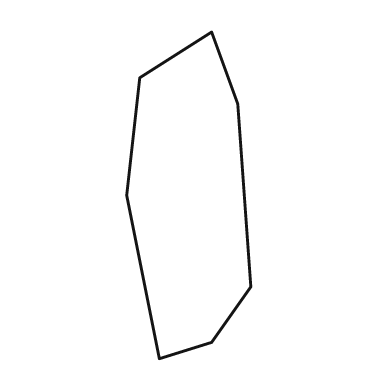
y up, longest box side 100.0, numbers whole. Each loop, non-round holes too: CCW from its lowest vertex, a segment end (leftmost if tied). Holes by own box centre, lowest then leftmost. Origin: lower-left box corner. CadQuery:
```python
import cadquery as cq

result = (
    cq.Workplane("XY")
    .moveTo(10.0, 0.0)
    .lineTo(26.0, 5.0)
    .lineTo(38.0, 22.0)
    .lineTo(34.0, 78.0)
    .lineTo(26.0, 100.0)
    .lineTo(4.0, 86.0)
    .lineTo(0.0, 50.0)
    .close()
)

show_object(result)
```